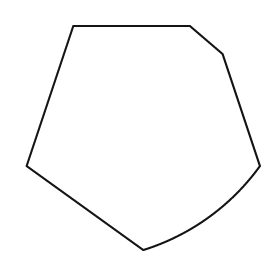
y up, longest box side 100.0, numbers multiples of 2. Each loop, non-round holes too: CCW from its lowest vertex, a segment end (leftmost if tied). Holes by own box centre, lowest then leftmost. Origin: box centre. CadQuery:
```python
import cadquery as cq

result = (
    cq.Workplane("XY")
    .moveTo(0.0, -48.0)
    .threePointArc((28.0, -34.0), (50.0, -12.0))
    .lineTo(34.0, 36.0)
    .lineTo(20.0, 48.0)
    .lineTo(-30.0, 48.0)
    .lineTo(-50.0, -12.0)
    .close()
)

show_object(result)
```